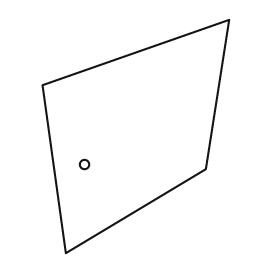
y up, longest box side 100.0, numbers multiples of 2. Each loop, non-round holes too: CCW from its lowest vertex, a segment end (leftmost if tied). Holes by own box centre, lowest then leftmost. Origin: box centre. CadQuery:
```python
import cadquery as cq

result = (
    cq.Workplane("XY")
    .moveTo(-30.0, -50.0)
    .lineTo(30.0, -14.0)
    .lineTo(40.0, 50.0)
    .lineTo(-40.0, 22.0)
    .close()
    .moveTo(-22.0, -12.0)
    .circle(2.0)
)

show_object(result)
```